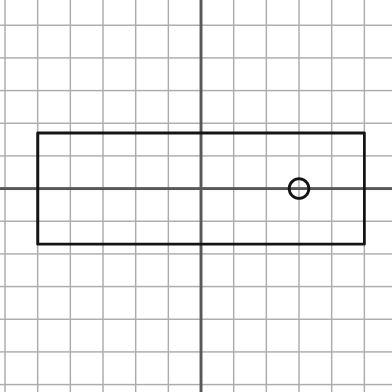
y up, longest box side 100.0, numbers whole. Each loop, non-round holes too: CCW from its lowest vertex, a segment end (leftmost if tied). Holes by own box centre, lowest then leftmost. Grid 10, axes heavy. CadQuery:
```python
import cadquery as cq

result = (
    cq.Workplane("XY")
    .moveTo(-50.0, -17.0)
    .lineTo(50.0, -17.0)
    .lineTo(50.0, 17.0)
    .lineTo(-50.0, 17.0)
    .close()
    .moveTo(30.0, 0.0)
    .circle(3.0)
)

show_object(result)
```